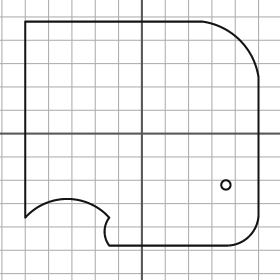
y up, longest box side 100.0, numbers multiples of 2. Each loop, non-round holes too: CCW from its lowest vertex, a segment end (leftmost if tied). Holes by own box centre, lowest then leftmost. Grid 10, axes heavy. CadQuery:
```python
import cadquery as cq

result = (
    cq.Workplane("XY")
    .moveTo(-14.0, -48.0)
    .lineTo(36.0, -48.0)
    .threePointArc((46.0, -44.0), (50.0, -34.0))
    .lineTo(50.0, 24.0)
    .threePointArc((42.0, 40.0), (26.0, 48.0))
    .lineTo(-50.0, 48.0)
    .lineTo(-50.0, -36.0)
    .threePointArc((-32.0, -28.0), (-14.0, -36.0))
    .threePointArc((-16.0, -42.0), (-14.0, -48.0))
    .close()
    .moveTo(36.0, -22.0)
    .circle(2.0)
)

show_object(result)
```